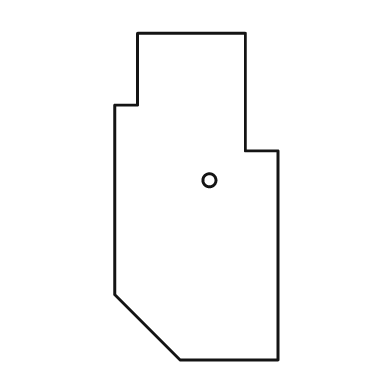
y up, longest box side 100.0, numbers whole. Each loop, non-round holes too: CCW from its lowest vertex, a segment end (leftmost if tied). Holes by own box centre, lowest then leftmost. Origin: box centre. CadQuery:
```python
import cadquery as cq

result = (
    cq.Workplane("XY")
    .moveTo(-5.0, -50.0)
    .lineTo(25.0, -50.0)
    .lineTo(25.0, 14.0)
    .lineTo(15.0, 14.0)
    .lineTo(15.0, 50.0)
    .lineTo(-18.0, 50.0)
    .lineTo(-18.0, 28.0)
    .lineTo(-25.0, 28.0)
    .lineTo(-25.0, -30.0)
    .close()
    .moveTo(4.0, 5.0)
    .circle(2.0)
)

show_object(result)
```